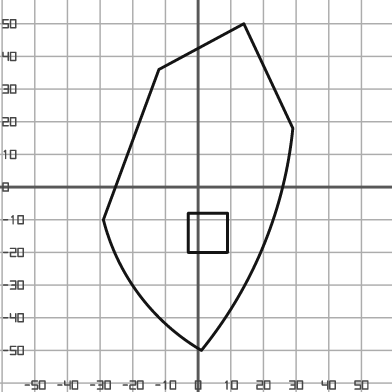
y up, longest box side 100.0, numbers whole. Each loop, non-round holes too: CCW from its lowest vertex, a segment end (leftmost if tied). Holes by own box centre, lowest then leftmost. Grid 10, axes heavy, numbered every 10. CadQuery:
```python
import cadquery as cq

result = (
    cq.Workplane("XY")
    .moveTo(1.0, -50.0)
    .threePointArc((20.0, -18.0), (29.0, 18.0))
    .lineTo(14.0, 50.0)
    .lineTo(-12.0, 36.0)
    .lineTo(-29.0, -10.0)
    .threePointArc((-18.0, -33.0), (1.0, -50.0))
    .close()
    .moveTo(-3.0, -20.0)
    .lineTo(9.0, -20.0)
    .lineTo(9.0, -8.0)
    .lineTo(-3.0, -8.0)
    .close()
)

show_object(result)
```